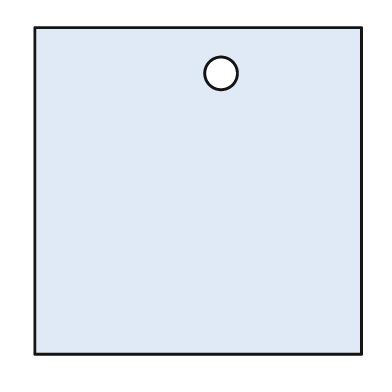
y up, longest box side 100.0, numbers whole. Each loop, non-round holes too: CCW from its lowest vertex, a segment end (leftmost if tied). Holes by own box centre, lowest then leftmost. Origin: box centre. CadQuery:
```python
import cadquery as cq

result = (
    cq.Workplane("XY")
    .moveTo(-50.0, -50.0)
    .lineTo(50.0, -50.0)
    .lineTo(50.0, 50.0)
    .lineTo(-50.0, 50.0)
    .close()
    .moveTo(7.0, 36.0)
    .circle(5.0)
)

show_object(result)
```